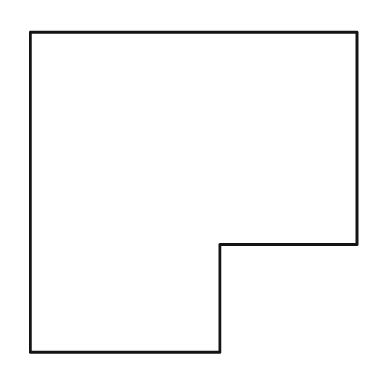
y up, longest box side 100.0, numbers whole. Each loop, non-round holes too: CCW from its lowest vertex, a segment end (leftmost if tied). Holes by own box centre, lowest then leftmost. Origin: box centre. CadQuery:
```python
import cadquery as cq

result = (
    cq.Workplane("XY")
    .moveTo(-50.0, -49.0)
    .lineTo(8.0, -49.0)
    .lineTo(8.0, -16.0)
    .lineTo(50.0, -16.0)
    .lineTo(50.0, 49.0)
    .lineTo(-50.0, 49.0)
    .close()
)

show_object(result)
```